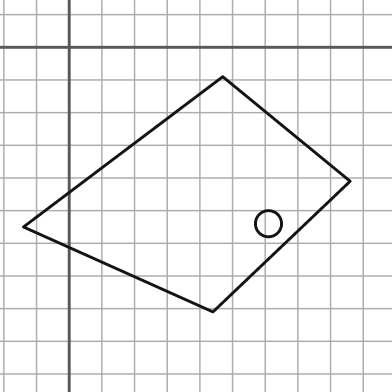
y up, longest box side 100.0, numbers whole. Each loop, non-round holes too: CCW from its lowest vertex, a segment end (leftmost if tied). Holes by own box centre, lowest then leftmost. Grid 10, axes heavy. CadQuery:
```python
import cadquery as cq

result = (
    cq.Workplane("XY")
    .moveTo(44.0, -81.0)
    .lineTo(86.0, -41.0)
    .lineTo(47.0, -9.0)
    .lineTo(-14.0, -55.0)
    .close()
    .moveTo(61.0, -54.0)
    .circle(4.0)
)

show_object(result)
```